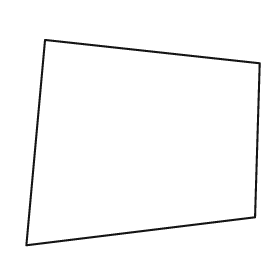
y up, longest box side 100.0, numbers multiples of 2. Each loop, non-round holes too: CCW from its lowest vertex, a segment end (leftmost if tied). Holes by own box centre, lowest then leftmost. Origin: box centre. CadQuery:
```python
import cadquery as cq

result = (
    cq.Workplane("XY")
    .moveTo(-50.0, -44.0)
    .lineTo(48.0, -32.0)
    .lineTo(50.0, 34.0)
    .lineTo(-42.0, 44.0)
    .close()
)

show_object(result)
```